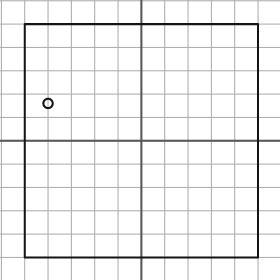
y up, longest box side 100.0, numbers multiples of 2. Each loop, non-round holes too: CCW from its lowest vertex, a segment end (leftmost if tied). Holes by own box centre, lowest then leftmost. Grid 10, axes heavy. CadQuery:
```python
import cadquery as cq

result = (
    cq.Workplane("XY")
    .moveTo(-50.0, -50.0)
    .lineTo(50.0, -50.0)
    .lineTo(50.0, 50.0)
    .lineTo(-50.0, 50.0)
    .close()
    .moveTo(-40.0, 16.0)
    .circle(2.0)
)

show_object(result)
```